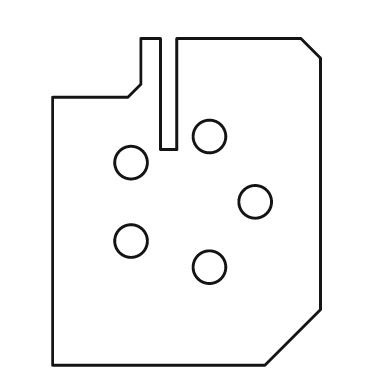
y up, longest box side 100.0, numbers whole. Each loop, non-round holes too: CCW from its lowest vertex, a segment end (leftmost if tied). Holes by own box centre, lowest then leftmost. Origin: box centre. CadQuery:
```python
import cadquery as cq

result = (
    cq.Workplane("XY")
    .moveTo(-41.0, -50.0)
    .lineTo(24.0, -50.0)
    .lineTo(41.0, -33.0)
    .lineTo(41.0, 44.0)
    .lineTo(35.0, 50.0)
    .lineTo(-3.0, 50.0)
    .lineTo(-3.0, 16.0)
    .lineTo(-8.0, 16.0)
    .lineTo(-8.0, 50.0)
    .lineTo(-14.0, 50.0)
    .lineTo(-14.0, 36.0)
    .lineTo(-18.0, 32.0)
    .lineTo(-41.0, 32.0)
    .close()
    .moveTo(7.0, -20.0)
    .circle(5.0)
    .moveTo(-17.0, -12.0)
    .circle(5.0)
    .moveTo(21.0, 0.0)
    .circle(5.0)
    .moveTo(-17.0, 12.0)
    .circle(5.0)
    .moveTo(7.0, 20.0)
    .circle(5.0)
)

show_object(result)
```